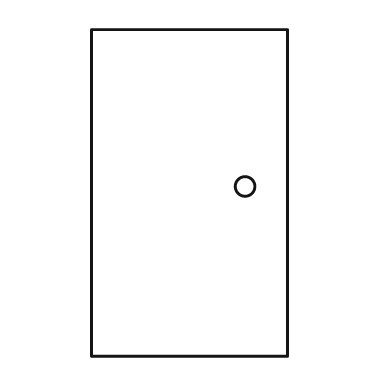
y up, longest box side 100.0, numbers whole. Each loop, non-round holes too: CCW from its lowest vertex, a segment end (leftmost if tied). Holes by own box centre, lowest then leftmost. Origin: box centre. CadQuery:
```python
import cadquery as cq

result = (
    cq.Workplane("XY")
    .moveTo(-30.0, -50.0)
    .lineTo(30.0, -50.0)
    .lineTo(30.0, 50.0)
    .lineTo(-30.0, 50.0)
    .close()
    .moveTo(17.0, 2.0)
    .circle(3.0)
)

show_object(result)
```